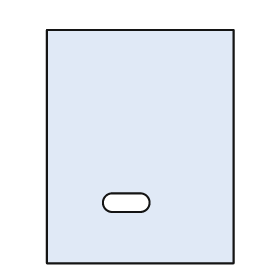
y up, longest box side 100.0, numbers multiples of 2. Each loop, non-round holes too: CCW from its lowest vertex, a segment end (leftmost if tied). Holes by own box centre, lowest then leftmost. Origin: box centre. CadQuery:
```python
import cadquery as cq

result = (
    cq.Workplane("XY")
    .moveTo(-40.0, -50.0)
    .lineTo(40.0, -50.0)
    .lineTo(40.0, 50.0)
    .lineTo(-40.0, 50.0)
    .close()
    .moveTo(-12.0, -28.0)
    .lineTo(0.0, -28.0)
    .threePointArc((4.0, -24.0), (0.0, -20.0))
    .lineTo(-12.0, -20.0)
    .threePointArc((-16.0, -24.0), (-12.0, -28.0))
    .close()
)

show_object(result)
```